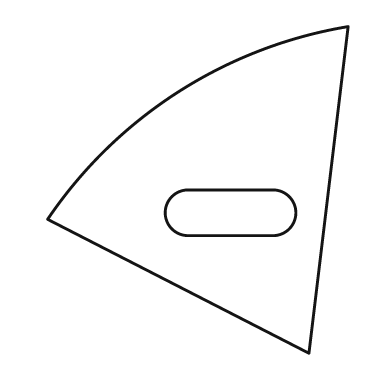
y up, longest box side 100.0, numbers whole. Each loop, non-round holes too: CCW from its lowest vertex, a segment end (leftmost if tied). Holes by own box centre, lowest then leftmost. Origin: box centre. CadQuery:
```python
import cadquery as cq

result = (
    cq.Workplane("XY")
    .moveTo(34.0, -50.0)
    .lineTo(46.0, 50.0)
    .threePointArc((-6.0, 30.0), (-46.0, -9.0))
    .close()
    .moveTo(-3.0, -14.0)
    .lineTo(23.0, -14.0)
    .threePointArc((30.0, -7.0), (23.0, 0.0))
    .lineTo(-3.0, 0.0)
    .threePointArc((-10.0, -7.0), (-3.0, -14.0))
    .close()
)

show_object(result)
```